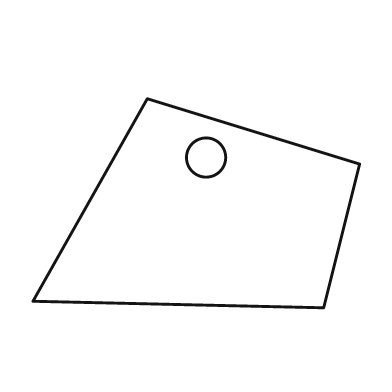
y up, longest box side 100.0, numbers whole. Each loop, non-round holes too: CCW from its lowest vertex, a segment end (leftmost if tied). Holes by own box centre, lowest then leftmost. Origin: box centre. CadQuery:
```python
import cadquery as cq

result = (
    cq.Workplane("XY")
    .moveTo(39.0, -32.0)
    .lineTo(50.0, 12.0)
    .lineTo(-15.0, 32.0)
    .lineTo(-50.0, -30.0)
    .close()
    .moveTo(3.0, 14.0)
    .circle(6.0)
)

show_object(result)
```